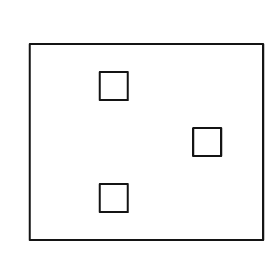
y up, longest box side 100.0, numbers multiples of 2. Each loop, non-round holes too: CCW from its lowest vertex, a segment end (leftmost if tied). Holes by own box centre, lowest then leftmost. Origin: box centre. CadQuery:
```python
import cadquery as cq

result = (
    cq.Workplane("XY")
    .moveTo(-50.0, -42.0)
    .lineTo(50.0, -42.0)
    .lineTo(50.0, 42.0)
    .lineTo(-50.0, 42.0)
    .close()
    .moveTo(-20.0, -30.0)
    .lineTo(-8.0, -30.0)
    .lineTo(-8.0, -18.0)
    .lineTo(-20.0, -18.0)
    .close()
    .moveTo(20.0, -6.0)
    .lineTo(32.0, -6.0)
    .lineTo(32.0, 6.0)
    .lineTo(20.0, 6.0)
    .close()
    .moveTo(-20.0, 18.0)
    .lineTo(-8.0, 18.0)
    .lineTo(-8.0, 30.0)
    .lineTo(-20.0, 30.0)
    .close()
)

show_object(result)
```